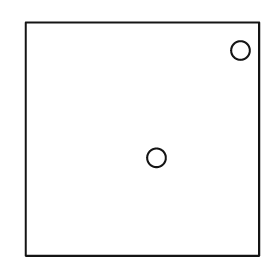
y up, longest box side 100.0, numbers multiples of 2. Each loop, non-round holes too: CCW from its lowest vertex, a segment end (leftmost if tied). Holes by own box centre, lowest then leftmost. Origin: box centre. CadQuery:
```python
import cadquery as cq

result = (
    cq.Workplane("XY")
    .moveTo(-50.0, -50.0)
    .lineTo(50.0, -50.0)
    .lineTo(50.0, 50.0)
    .lineTo(-50.0, 50.0)
    .close()
    .moveTo(6.0, -8.0)
    .circle(4.0)
    .moveTo(42.0, 38.0)
    .circle(4.0)
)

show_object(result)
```